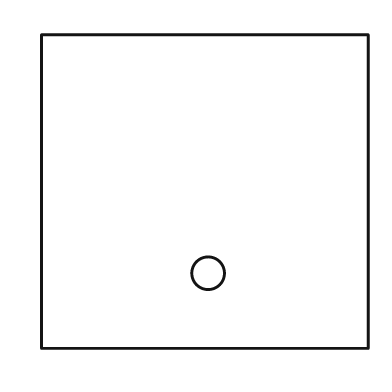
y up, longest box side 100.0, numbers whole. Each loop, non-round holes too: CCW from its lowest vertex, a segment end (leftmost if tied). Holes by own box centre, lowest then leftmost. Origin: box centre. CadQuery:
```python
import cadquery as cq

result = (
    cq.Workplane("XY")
    .moveTo(-50.0, -48.0)
    .lineTo(50.0, -48.0)
    .lineTo(50.0, 48.0)
    .lineTo(-50.0, 48.0)
    .close()
    .moveTo(1.0, -25.0)
    .circle(5.0)
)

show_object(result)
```